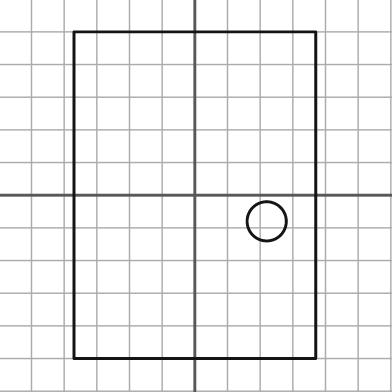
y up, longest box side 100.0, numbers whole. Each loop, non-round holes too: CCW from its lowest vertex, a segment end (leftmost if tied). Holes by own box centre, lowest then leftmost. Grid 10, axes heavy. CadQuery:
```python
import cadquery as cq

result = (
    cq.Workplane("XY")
    .moveTo(-37.0, -50.0)
    .lineTo(37.0, -50.0)
    .lineTo(37.0, 50.0)
    .lineTo(-37.0, 50.0)
    .close()
    .moveTo(22.0, -8.0)
    .circle(6.0)
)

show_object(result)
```